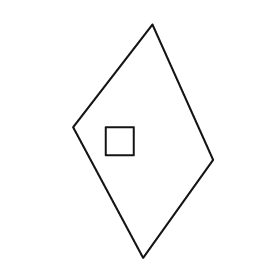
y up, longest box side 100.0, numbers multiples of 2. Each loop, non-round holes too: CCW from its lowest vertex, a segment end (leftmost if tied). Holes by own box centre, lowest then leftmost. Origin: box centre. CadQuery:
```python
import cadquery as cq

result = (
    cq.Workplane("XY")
    .moveTo(0.0, -50.0)
    .lineTo(30.0, -8.0)
    .lineTo(4.0, 50.0)
    .lineTo(-30.0, 6.0)
    .close()
    .moveTo(-16.0, -6.0)
    .lineTo(-4.0, -6.0)
    .lineTo(-4.0, 6.0)
    .lineTo(-16.0, 6.0)
    .close()
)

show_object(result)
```